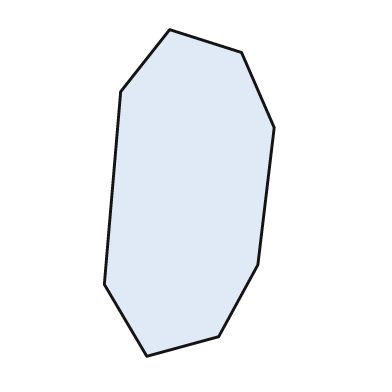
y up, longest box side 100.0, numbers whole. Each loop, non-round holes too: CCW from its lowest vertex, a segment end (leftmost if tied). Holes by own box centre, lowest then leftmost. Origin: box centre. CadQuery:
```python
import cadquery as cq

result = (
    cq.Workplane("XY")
    .moveTo(-13.0, -50.0)
    .lineTo(9.0, -44.0)
    .lineTo(21.0, -22.0)
    .lineTo(26.0, 20.0)
    .lineTo(16.0, 43.0)
    .lineTo(-6.0, 50.0)
    .lineTo(-21.0, 31.0)
    .lineTo(-26.0, -28.0)
    .close()
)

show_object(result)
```